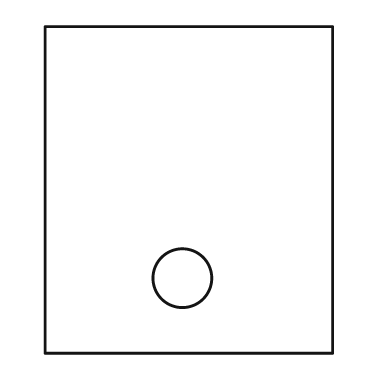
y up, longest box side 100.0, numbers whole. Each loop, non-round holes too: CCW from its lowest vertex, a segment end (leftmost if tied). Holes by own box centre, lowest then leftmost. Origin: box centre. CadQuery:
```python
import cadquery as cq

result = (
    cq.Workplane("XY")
    .moveTo(-44.0, -50.0)
    .lineTo(44.0, -50.0)
    .lineTo(44.0, 50.0)
    .lineTo(-44.0, 50.0)
    .close()
    .moveTo(-2.0, -27.0)
    .circle(9.0)
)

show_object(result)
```